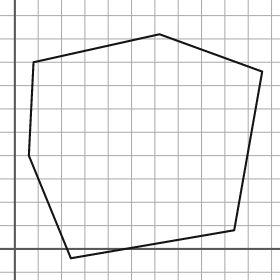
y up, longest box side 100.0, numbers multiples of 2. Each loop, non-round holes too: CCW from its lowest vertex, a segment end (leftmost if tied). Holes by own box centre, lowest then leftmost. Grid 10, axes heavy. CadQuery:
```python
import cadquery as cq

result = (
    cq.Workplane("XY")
    .moveTo(24.0, -4.0)
    .lineTo(94.0, 8.0)
    .lineTo(106.0, 76.0)
    .lineTo(62.0, 92.0)
    .lineTo(8.0, 80.0)
    .lineTo(6.0, 40.0)
    .close()
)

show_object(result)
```